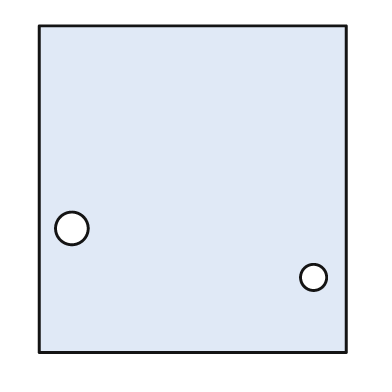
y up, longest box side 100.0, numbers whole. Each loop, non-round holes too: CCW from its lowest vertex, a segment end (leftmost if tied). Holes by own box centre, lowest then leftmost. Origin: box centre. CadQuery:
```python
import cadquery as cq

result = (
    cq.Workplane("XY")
    .moveTo(-47.0, -50.0)
    .lineTo(47.0, -50.0)
    .lineTo(47.0, 50.0)
    .lineTo(-47.0, 50.0)
    .close()
    .moveTo(37.0, -27.0)
    .circle(4.0)
    .moveTo(-37.0, -12.0)
    .circle(5.0)
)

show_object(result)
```